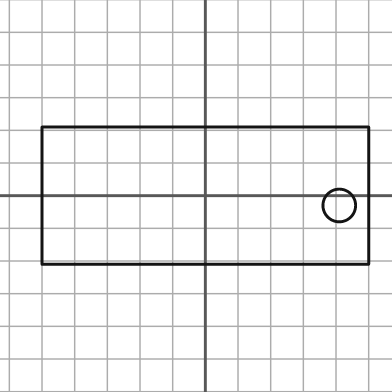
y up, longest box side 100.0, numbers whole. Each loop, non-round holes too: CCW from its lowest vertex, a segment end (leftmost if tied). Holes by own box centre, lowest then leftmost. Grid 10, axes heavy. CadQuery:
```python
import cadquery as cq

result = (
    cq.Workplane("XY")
    .moveTo(-50.0, -21.0)
    .lineTo(50.0, -21.0)
    .lineTo(50.0, 21.0)
    .lineTo(-50.0, 21.0)
    .close()
    .moveTo(41.0, -3.0)
    .circle(5.0)
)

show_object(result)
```